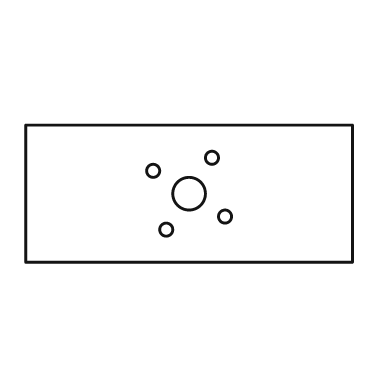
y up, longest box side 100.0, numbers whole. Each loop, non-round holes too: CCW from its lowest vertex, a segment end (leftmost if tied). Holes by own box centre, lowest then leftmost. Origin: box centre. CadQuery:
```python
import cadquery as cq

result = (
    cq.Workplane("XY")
    .moveTo(-50.0, -21.0)
    .lineTo(50.0, -21.0)
    .lineTo(50.0, 21.0)
    .lineTo(-50.0, 21.0)
    .close()
    .moveTo(-7.0, -11.0)
    .circle(2.0)
    .moveTo(11.0, -7.0)
    .circle(2.0)
    .moveTo(0.0, 0.0)
    .circle(5.0)
    .moveTo(-11.0, 7.0)
    .circle(2.0)
    .moveTo(7.0, 11.0)
    .circle(2.0)
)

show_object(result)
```